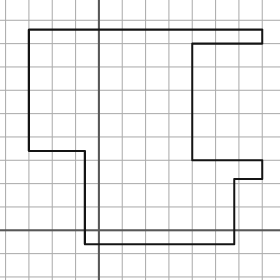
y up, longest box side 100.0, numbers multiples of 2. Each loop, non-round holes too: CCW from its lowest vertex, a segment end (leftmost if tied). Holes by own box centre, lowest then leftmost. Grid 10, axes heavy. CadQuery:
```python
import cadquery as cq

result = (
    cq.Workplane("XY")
    .moveTo(-6.0, -6.0)
    .lineTo(58.0, -6.0)
    .lineTo(58.0, 22.0)
    .lineTo(70.0, 22.0)
    .lineTo(70.0, 30.0)
    .lineTo(40.0, 30.0)
    .lineTo(40.0, 80.0)
    .lineTo(70.0, 80.0)
    .lineTo(70.0, 86.0)
    .lineTo(-30.0, 86.0)
    .lineTo(-30.0, 34.0)
    .lineTo(-6.0, 34.0)
    .close()
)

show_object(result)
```